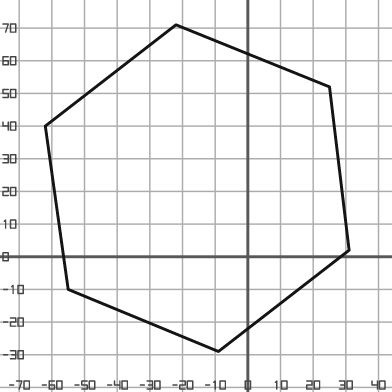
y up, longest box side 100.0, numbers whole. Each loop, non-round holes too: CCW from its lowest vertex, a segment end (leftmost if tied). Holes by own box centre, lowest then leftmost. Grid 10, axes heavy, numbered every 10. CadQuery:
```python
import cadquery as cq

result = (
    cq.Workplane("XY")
    .moveTo(-9.0, -29.0)
    .lineTo(31.0, 2.0)
    .lineTo(25.0, 52.0)
    .lineTo(-22.0, 71.0)
    .lineTo(-62.0, 40.0)
    .lineTo(-55.0, -10.0)
    .close()
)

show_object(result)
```